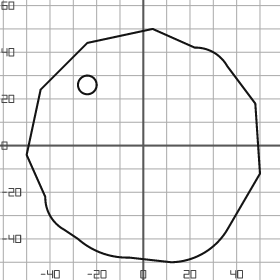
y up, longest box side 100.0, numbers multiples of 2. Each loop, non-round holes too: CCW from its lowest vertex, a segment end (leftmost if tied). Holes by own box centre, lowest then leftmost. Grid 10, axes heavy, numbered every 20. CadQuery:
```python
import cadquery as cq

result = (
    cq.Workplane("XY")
    .moveTo(12.0, -50.0)
    .threePointArc((26.0, -46.0), (36.0, -36.0))
    .lineTo(50.0, -12.0)
    .lineTo(48.0, 18.0)
    .lineTo(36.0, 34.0)
    .threePointArc((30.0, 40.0), (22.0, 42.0))
    .lineTo(4.0, 50.0)
    .lineTo(-24.0, 44.0)
    .lineTo(-44.0, 24.0)
    .lineTo(-50.0, -4.0)
    .lineTo(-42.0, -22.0)
    .threePointArc((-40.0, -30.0), (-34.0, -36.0))
    .lineTo(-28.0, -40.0)
    .threePointArc((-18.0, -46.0), (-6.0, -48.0))
    .close()
    .moveTo(-24.0, 26.0)
    .circle(4.0)
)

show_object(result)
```